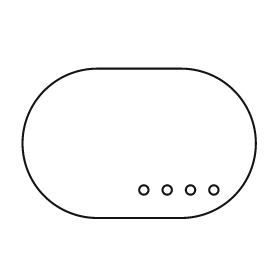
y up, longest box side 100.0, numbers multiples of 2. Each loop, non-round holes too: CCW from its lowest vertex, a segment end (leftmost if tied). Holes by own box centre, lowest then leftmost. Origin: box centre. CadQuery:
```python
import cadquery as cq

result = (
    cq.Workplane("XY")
    .moveTo(-18.0, -32.0)
    .lineTo(18.0, -32.0)
    .threePointArc((50.0, 0.0), (18.0, 32.0))
    .lineTo(-18.0, 32.0)
    .threePointArc((-50.0, 0.0), (-18.0, -32.0))
    .close()
    .moveTo(2.0, -20.0)
    .circle(2.0)
    .moveTo(12.0, -20.0)
    .circle(2.0)
    .moveTo(22.0, -20.0)
    .circle(2.0)
    .moveTo(32.0, -20.0)
    .circle(2.0)
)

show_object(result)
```